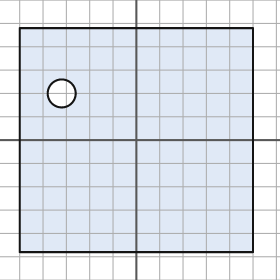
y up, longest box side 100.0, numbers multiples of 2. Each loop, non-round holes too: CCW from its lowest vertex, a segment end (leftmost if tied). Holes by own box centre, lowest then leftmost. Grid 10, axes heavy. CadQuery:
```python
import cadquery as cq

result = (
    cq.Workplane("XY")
    .moveTo(-50.0, -48.0)
    .lineTo(50.0, -48.0)
    .lineTo(50.0, 48.0)
    .lineTo(-50.0, 48.0)
    .close()
    .moveTo(-32.0, 20.0)
    .circle(6.0)
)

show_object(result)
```